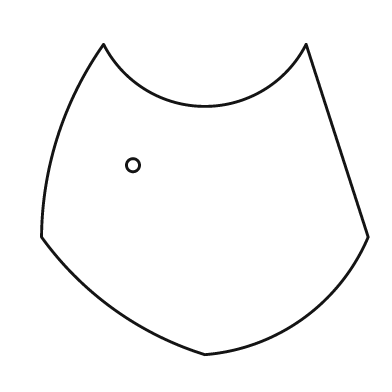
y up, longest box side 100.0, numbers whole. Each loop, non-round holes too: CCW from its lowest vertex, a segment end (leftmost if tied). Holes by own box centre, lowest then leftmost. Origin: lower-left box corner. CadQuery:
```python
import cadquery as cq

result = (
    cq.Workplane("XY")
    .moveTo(50.0, 0.0)
    .threePointArc((80.0, 11.0), (100.0, 36.0))
    .lineTo(81.0, 95.0)
    .threePointArc((50.0, 76.0), (19.0, 95.0))
    .threePointArc((5.0, 67.0), (0.0, 36.0))
    .threePointArc((22.0, 14.0), (50.0, 0.0))
    .close()
    .moveTo(28.0, 58.0)
    .circle(2.0)
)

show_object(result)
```